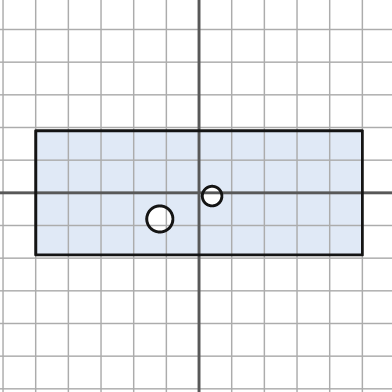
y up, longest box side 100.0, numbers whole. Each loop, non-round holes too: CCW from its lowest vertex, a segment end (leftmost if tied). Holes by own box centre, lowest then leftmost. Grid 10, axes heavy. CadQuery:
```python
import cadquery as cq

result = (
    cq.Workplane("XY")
    .moveTo(-50.0, -19.0)
    .lineTo(50.0, -19.0)
    .lineTo(50.0, 19.0)
    .lineTo(-50.0, 19.0)
    .close()
    .moveTo(-12.0, -8.0)
    .circle(4.0)
    .moveTo(4.0, -1.0)
    .circle(3.0)
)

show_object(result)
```